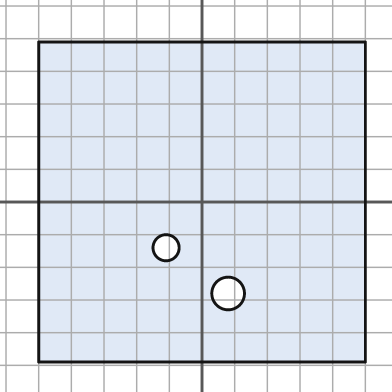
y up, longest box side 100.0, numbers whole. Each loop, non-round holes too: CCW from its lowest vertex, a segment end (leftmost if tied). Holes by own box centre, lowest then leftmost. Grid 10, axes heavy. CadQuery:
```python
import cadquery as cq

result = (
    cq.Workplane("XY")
    .moveTo(-50.0, -49.0)
    .lineTo(50.0, -49.0)
    .lineTo(50.0, 49.0)
    .lineTo(-50.0, 49.0)
    .close()
    .moveTo(8.0, -28.0)
    .circle(5.0)
    .moveTo(-11.0, -14.0)
    .circle(4.0)
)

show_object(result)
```